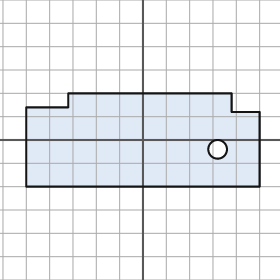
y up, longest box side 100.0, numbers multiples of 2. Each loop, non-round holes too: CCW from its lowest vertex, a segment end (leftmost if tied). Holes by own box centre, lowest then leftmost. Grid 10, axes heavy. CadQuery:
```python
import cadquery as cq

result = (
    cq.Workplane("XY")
    .moveTo(-50.0, -20.0)
    .lineTo(50.0, -20.0)
    .lineTo(50.0, 12.0)
    .lineTo(38.0, 12.0)
    .lineTo(38.0, 20.0)
    .lineTo(-32.0, 20.0)
    .lineTo(-32.0, 14.0)
    .lineTo(-50.0, 14.0)
    .close()
    .moveTo(32.0, -4.0)
    .circle(4.0)
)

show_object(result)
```